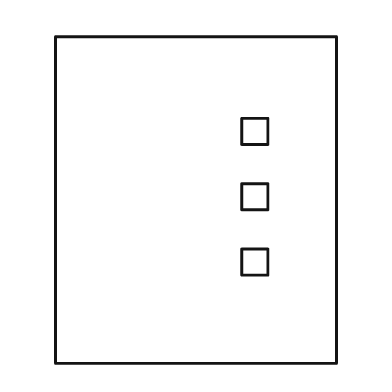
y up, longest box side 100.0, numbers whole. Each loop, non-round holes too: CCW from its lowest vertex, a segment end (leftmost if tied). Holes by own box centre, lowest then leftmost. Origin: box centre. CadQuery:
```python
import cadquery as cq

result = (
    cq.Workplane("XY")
    .moveTo(-43.0, -50.0)
    .lineTo(43.0, -50.0)
    .lineTo(43.0, 50.0)
    .lineTo(-43.0, 50.0)
    .close()
    .moveTo(14.0, -23.0)
    .lineTo(22.0, -23.0)
    .lineTo(22.0, -15.0)
    .lineTo(14.0, -15.0)
    .close()
    .moveTo(14.0, -3.0)
    .lineTo(22.0, -3.0)
    .lineTo(22.0, 5.0)
    .lineTo(14.0, 5.0)
    .close()
    .moveTo(14.0, 17.0)
    .lineTo(22.0, 17.0)
    .lineTo(22.0, 25.0)
    .lineTo(14.0, 25.0)
    .close()
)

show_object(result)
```